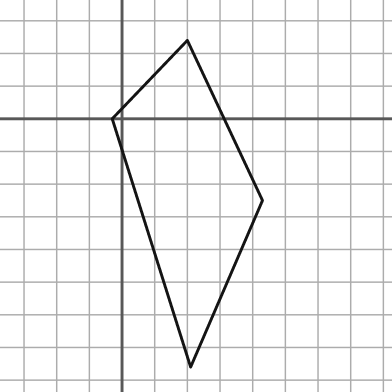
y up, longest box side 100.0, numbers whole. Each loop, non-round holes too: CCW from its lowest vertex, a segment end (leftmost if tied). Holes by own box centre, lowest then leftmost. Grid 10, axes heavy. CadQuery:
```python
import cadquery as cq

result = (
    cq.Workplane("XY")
    .moveTo(21.0, -76.0)
    .lineTo(43.0, -25.0)
    .lineTo(20.0, 24.0)
    .lineTo(-3.0, 0.0)
    .close()
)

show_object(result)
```